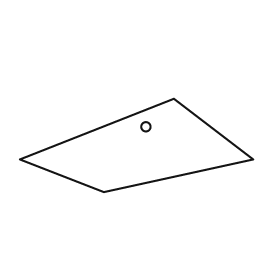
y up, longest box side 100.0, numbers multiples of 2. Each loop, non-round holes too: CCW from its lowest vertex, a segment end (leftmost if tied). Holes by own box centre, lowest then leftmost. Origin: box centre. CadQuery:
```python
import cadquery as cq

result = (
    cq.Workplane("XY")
    .moveTo(-14.0, -20.0)
    .lineTo(50.0, -6.0)
    .lineTo(16.0, 20.0)
    .lineTo(-50.0, -6.0)
    .close()
    .moveTo(4.0, 8.0)
    .circle(2.0)
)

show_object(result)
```